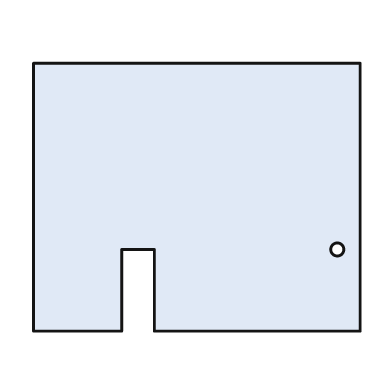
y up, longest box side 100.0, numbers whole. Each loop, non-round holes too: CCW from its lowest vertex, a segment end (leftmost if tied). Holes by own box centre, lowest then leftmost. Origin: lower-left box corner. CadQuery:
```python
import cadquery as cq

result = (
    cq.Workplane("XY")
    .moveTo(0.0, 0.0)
    .lineTo(27.0, 0.0)
    .lineTo(27.0, 25.0)
    .lineTo(37.0, 25.0)
    .lineTo(37.0, 0.0)
    .lineTo(100.0, 0.0)
    .lineTo(100.0, 82.0)
    .lineTo(0.0, 82.0)
    .close()
    .moveTo(93.0, 25.0)
    .circle(2.0)
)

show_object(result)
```